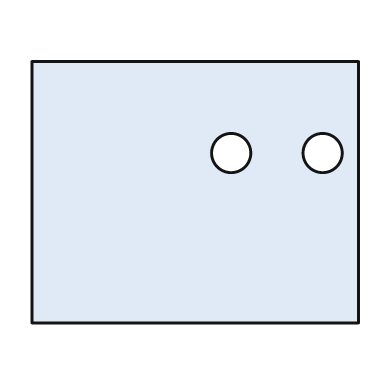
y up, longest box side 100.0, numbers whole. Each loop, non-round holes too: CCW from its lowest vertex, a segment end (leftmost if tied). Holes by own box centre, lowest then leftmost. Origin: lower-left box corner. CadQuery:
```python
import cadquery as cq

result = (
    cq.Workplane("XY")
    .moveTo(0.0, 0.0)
    .lineTo(100.0, 0.0)
    .lineTo(100.0, 80.0)
    .lineTo(0.0, 80.0)
    .close()
    .moveTo(61.0, 52.0)
    .circle(6.0)
    .moveTo(89.0, 52.0)
    .circle(6.0)
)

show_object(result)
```